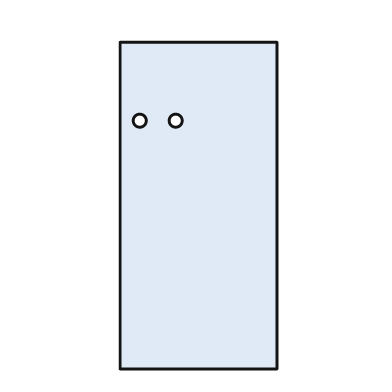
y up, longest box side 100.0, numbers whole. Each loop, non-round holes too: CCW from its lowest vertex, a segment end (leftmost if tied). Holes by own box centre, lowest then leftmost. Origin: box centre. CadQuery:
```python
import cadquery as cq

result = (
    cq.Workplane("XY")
    .moveTo(-24.0, -50.0)
    .lineTo(24.0, -50.0)
    .lineTo(24.0, 50.0)
    .lineTo(-24.0, 50.0)
    .close()
    .moveTo(-18.0, 26.0)
    .circle(2.0)
    .moveTo(-7.0, 26.0)
    .circle(2.0)
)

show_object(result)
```